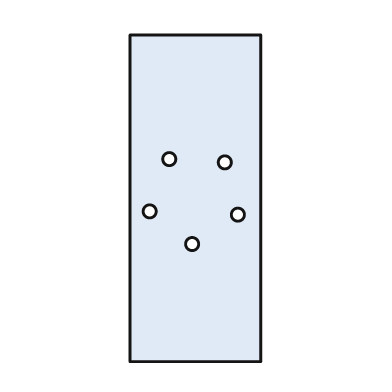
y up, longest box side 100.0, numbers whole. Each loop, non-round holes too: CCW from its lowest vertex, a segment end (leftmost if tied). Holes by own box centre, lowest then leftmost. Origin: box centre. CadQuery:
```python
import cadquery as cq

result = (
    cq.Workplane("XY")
    .moveTo(-20.0, -50.0)
    .lineTo(20.0, -50.0)
    .lineTo(20.0, 50.0)
    .lineTo(-20.0, 50.0)
    .close()
    .moveTo(-1.0, -14.0)
    .circle(2.0)
    .moveTo(13.0, -5.0)
    .circle(2.0)
    .moveTo(-14.0, -4.0)
    .circle(2.0)
    .moveTo(9.0, 11.0)
    .circle(2.0)
    .moveTo(-8.0, 12.0)
    .circle(2.0)
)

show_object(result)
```